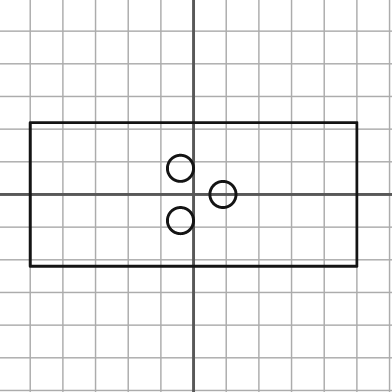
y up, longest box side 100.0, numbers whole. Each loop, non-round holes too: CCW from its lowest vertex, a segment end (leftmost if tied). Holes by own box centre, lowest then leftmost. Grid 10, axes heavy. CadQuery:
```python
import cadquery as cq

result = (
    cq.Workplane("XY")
    .moveTo(-50.0, -22.0)
    .lineTo(50.0, -22.0)
    .lineTo(50.0, 22.0)
    .lineTo(-50.0, 22.0)
    .close()
    .moveTo(-4.0, -8.0)
    .circle(4.0)
    .moveTo(9.0, 0.0)
    .circle(4.0)
    .moveTo(-4.0, 8.0)
    .circle(4.0)
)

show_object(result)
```